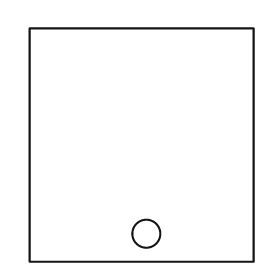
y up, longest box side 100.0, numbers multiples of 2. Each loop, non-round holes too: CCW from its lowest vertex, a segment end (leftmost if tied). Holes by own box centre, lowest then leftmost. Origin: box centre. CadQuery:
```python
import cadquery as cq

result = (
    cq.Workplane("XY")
    .moveTo(-48.0, -50.0)
    .lineTo(48.0, -50.0)
    .lineTo(48.0, 50.0)
    .lineTo(-48.0, 50.0)
    .close()
    .moveTo(2.0, -38.0)
    .circle(6.0)
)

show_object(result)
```